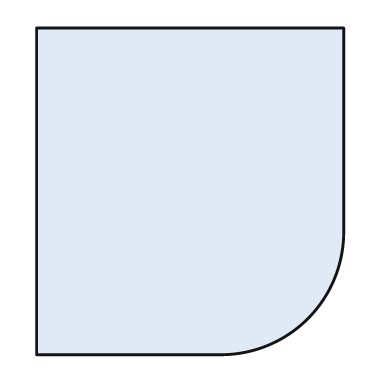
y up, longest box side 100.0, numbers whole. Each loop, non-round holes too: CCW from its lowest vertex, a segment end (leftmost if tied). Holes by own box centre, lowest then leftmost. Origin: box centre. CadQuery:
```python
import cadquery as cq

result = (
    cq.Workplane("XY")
    .moveTo(-47.0, -50.0)
    .lineTo(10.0, -50.0)
    .threePointArc((36.0, -39.0), (47.0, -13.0))
    .lineTo(47.0, 50.0)
    .lineTo(-47.0, 50.0)
    .close()
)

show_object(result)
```